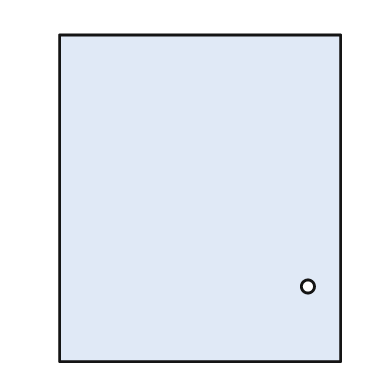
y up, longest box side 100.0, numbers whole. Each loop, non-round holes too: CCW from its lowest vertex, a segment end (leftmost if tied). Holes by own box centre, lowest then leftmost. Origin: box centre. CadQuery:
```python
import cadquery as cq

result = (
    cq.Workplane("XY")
    .moveTo(-43.0, -50.0)
    .lineTo(43.0, -50.0)
    .lineTo(43.0, 50.0)
    .lineTo(-43.0, 50.0)
    .close()
    .moveTo(33.0, -27.0)
    .circle(2.0)
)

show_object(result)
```